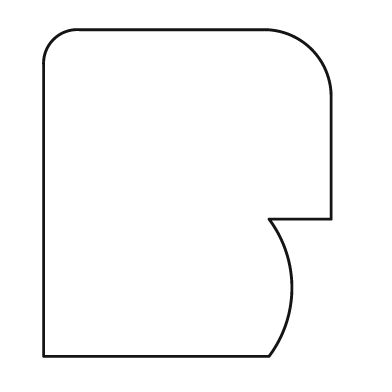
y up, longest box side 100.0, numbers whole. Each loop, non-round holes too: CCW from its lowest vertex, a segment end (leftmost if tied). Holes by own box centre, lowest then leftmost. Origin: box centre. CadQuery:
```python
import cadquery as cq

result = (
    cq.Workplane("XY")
    .moveTo(-44.0, -50.0)
    .lineTo(25.0, -50.0)
    .threePointArc((32.0, -29.0), (25.0, -8.0))
    .lineTo(44.0, -8.0)
    .lineTo(44.0, 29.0)
    .threePointArc((38.0, 44.0), (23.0, 50.0))
    .lineTo(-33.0, 50.0)
    .threePointArc((-41.0, 47.0), (-44.0, 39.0))
    .close()
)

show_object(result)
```